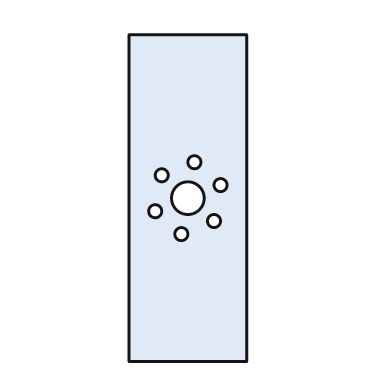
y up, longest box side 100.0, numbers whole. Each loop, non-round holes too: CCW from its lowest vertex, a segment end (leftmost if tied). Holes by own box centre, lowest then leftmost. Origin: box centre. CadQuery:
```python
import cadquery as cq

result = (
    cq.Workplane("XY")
    .moveTo(-18.0, -50.0)
    .lineTo(18.0, -50.0)
    .lineTo(18.0, 50.0)
    .lineTo(-18.0, 50.0)
    .close()
    .moveTo(-2.0, -11.0)
    .circle(2.0)
    .moveTo(8.0, -7.0)
    .circle(2.0)
    .moveTo(-10.0, -4.0)
    .circle(2.0)
    .moveTo(0.0, 0.0)
    .circle(5.0)
    .moveTo(10.0, 4.0)
    .circle(2.0)
    .moveTo(-8.0, 7.0)
    .circle(2.0)
    .moveTo(2.0, 11.0)
    .circle(2.0)
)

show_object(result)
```